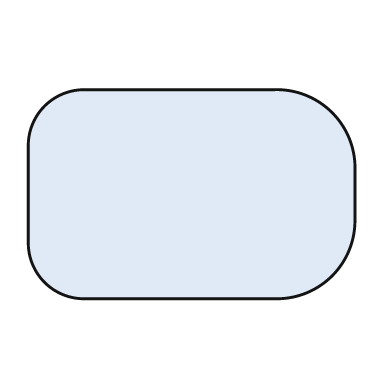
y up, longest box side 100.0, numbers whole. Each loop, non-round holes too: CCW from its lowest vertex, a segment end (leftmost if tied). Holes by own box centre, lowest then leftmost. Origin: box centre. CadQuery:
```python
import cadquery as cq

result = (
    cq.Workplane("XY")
    .moveTo(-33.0, -32.0)
    .lineTo(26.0, -32.0)
    .threePointArc((43.0, -25.0), (50.0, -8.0))
    .lineTo(50.0, 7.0)
    .threePointArc((43.0, 25.0), (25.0, 32.0))
    .lineTo(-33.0, 32.0)
    .threePointArc((-45.0, 27.0), (-50.0, 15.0))
    .lineTo(-50.0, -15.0)
    .threePointArc((-45.0, -27.0), (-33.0, -32.0))
    .close()
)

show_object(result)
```